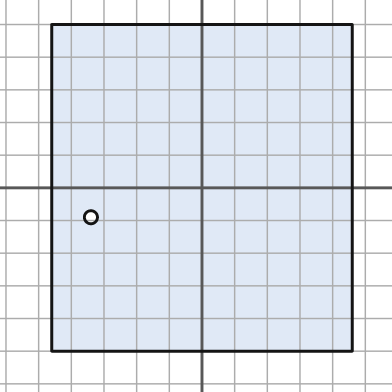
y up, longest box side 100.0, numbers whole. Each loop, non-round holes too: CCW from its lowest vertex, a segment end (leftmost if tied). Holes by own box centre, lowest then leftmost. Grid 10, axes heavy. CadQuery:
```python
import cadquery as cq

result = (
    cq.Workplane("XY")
    .moveTo(-46.0, -50.0)
    .lineTo(46.0, -50.0)
    .lineTo(46.0, 50.0)
    .lineTo(-46.0, 50.0)
    .close()
    .moveTo(-34.0, -9.0)
    .circle(2.0)
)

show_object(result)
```